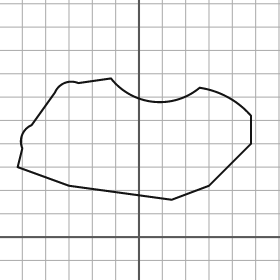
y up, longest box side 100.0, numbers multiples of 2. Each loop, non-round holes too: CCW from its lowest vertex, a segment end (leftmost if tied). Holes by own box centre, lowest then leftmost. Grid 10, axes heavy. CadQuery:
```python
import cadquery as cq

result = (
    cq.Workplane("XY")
    .moveTo(14.0, 16.0)
    .lineTo(30.0, 22.0)
    .lineTo(48.0, 40.0)
    .lineTo(48.0, 52.0)
    .threePointArc((38.0, 60.0), (26.0, 64.0))
    .threePointArc((6.0, 58.0), (-12.0, 68.0))
    .lineTo(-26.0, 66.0)
    .threePointArc((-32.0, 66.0), (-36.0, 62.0))
    .lineTo(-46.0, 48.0)
    .threePointArc((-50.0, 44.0), (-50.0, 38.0))
    .lineTo(-52.0, 30.0)
    .lineTo(-30.0, 22.0)
    .close()
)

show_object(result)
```